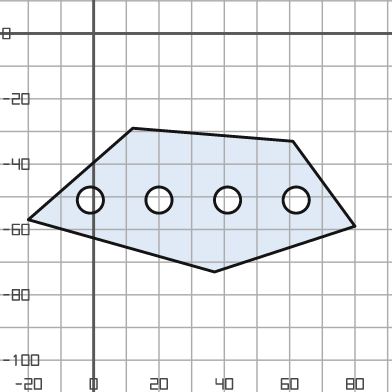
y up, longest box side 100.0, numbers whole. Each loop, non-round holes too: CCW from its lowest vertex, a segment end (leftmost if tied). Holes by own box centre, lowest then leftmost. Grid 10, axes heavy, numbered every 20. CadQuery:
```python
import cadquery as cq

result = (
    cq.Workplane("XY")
    .moveTo(37.0, -73.0)
    .lineTo(80.0, -59.0)
    .lineTo(61.0, -33.0)
    .lineTo(12.0, -29.0)
    .lineTo(-20.0, -57.0)
    .close()
    .moveTo(-1.0, -51.0)
    .circle(4.0)
    .moveTo(20.0, -51.0)
    .circle(4.0)
    .moveTo(41.0, -51.0)
    .circle(4.0)
    .moveTo(62.0, -51.0)
    .circle(4.0)
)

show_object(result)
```